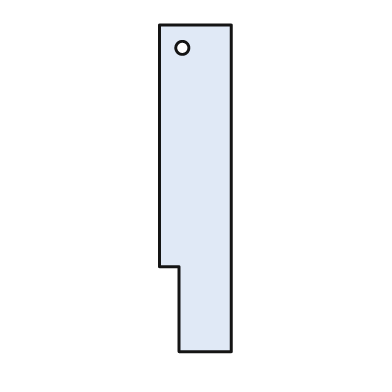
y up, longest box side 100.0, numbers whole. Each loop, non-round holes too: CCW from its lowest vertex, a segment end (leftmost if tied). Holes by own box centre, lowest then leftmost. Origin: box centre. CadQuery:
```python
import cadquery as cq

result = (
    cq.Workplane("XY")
    .moveTo(-5.0, -50.0)
    .lineTo(11.0, -50.0)
    .lineTo(11.0, 50.0)
    .lineTo(-11.0, 50.0)
    .lineTo(-11.0, -24.0)
    .lineTo(-5.0, -24.0)
    .close()
    .moveTo(-4.0, 43.0)
    .circle(2.0)
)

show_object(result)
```